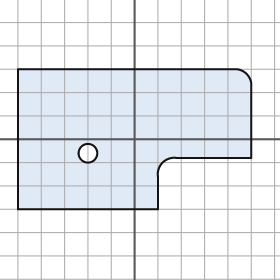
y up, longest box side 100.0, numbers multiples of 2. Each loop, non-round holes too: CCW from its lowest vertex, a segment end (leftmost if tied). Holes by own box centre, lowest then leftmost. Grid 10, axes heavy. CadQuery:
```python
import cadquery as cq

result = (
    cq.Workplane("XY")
    .moveTo(-50.0, -30.0)
    .lineTo(10.0, -30.0)
    .lineTo(10.0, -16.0)
    .threePointArc((12.0, -10.0), (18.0, -8.0))
    .lineTo(50.0, -8.0)
    .lineTo(50.0, 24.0)
    .threePointArc((48.0, 28.0), (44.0, 30.0))
    .lineTo(-50.0, 30.0)
    .close()
    .moveTo(-20.0, -6.0)
    .circle(4.0)
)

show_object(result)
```